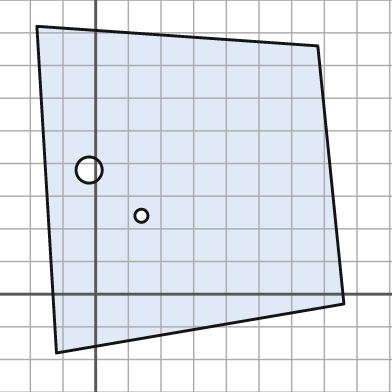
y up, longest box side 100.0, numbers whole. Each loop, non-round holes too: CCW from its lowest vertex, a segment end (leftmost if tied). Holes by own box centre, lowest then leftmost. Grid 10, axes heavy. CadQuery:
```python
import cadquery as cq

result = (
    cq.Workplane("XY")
    .moveTo(-12.0, -18.0)
    .lineTo(76.0, -3.0)
    .lineTo(68.0, 76.0)
    .lineTo(-18.0, 82.0)
    .close()
    .moveTo(14.0, 24.0)
    .circle(2.0)
    .moveTo(-2.0, 38.0)
    .circle(4.0)
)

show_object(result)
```